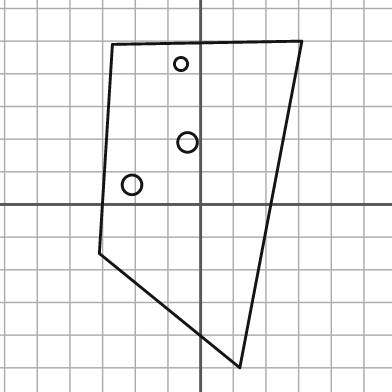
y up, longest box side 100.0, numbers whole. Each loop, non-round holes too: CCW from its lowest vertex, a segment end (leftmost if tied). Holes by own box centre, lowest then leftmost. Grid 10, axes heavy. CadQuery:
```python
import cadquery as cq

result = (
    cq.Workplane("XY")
    .moveTo(12.0, -50.0)
    .lineTo(31.0, 50.0)
    .lineTo(-27.0, 49.0)
    .lineTo(-31.0, -15.0)
    .close()
    .moveTo(-21.0, 6.0)
    .circle(3.0)
    .moveTo(-4.0, 19.0)
    .circle(3.0)
    .moveTo(-6.0, 43.0)
    .circle(2.0)
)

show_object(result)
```